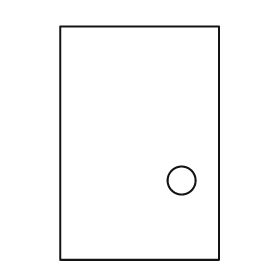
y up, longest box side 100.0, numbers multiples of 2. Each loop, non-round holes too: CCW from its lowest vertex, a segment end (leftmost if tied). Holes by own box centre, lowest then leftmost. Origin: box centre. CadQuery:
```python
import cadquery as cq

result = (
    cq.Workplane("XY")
    .moveTo(-34.0, -50.0)
    .lineTo(34.0, -50.0)
    .lineTo(34.0, 50.0)
    .lineTo(-34.0, 50.0)
    .close()
    .moveTo(18.0, -16.0)
    .circle(6.0)
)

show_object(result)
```